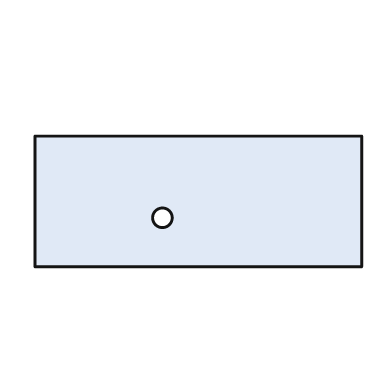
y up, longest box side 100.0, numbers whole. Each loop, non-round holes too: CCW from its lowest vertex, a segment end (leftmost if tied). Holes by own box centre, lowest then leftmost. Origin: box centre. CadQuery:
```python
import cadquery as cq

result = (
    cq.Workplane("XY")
    .moveTo(-50.0, -20.0)
    .lineTo(50.0, -20.0)
    .lineTo(50.0, 20.0)
    .lineTo(-50.0, 20.0)
    .close()
    .moveTo(-11.0, -5.0)
    .circle(3.0)
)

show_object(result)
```